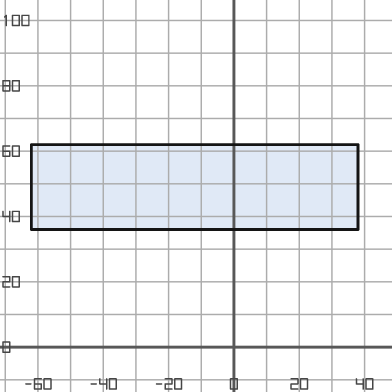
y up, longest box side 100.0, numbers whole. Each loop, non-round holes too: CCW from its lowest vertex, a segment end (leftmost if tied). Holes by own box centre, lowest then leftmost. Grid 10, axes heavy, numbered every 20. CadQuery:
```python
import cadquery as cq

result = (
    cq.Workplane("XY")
    .moveTo(-62.0, 36.0)
    .lineTo(38.0, 36.0)
    .lineTo(38.0, 62.0)
    .lineTo(-62.0, 62.0)
    .close()
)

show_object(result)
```